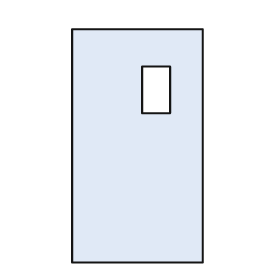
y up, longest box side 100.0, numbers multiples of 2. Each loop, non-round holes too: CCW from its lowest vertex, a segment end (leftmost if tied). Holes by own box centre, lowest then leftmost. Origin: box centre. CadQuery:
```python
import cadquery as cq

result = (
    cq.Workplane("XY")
    .moveTo(-28.0, -50.0)
    .lineTo(28.0, -50.0)
    .lineTo(28.0, 50.0)
    .lineTo(-28.0, 50.0)
    .close()
    .moveTo(2.0, 14.0)
    .lineTo(14.0, 14.0)
    .lineTo(14.0, 34.0)
    .lineTo(2.0, 34.0)
    .close()
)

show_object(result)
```